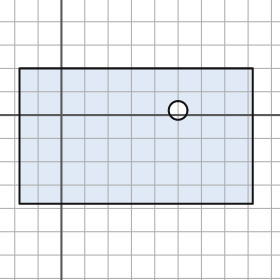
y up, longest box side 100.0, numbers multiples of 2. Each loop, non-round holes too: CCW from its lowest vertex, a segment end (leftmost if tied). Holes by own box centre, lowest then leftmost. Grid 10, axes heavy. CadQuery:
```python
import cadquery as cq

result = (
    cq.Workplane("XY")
    .moveTo(-18.0, -38.0)
    .lineTo(82.0, -38.0)
    .lineTo(82.0, 20.0)
    .lineTo(-18.0, 20.0)
    .close()
    .moveTo(50.0, 2.0)
    .circle(4.0)
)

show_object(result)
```